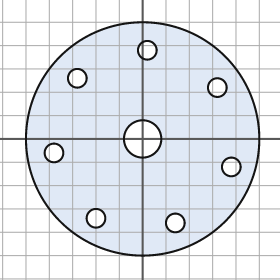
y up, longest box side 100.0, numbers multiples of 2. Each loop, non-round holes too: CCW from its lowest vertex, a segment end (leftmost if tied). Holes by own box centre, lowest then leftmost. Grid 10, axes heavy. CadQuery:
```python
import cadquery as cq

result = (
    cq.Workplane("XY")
    .moveTo(0.0, 0.0)
    .circle(50.0)
    .moveTo(14.0, -36.0)
    .circle(4.0)
    .moveTo(-20.0, -34.0)
    .circle(4.0)
    .moveTo(38.0, -12.0)
    .circle(4.0)
    .moveTo(-38.0, -6.0)
    .circle(4.0)
    .moveTo(0.0, 0.0)
    .circle(8.0)
    .moveTo(32.0, 22.0)
    .circle(4.0)
    .moveTo(-28.0, 26.0)
    .circle(4.0)
    .moveTo(2.0, 38.0)
    .circle(4.0)
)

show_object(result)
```